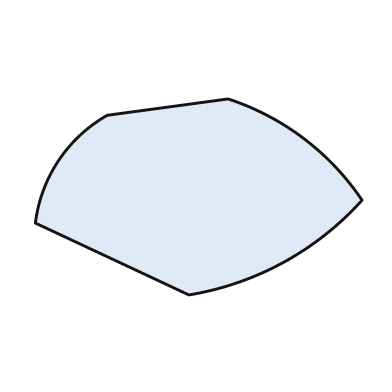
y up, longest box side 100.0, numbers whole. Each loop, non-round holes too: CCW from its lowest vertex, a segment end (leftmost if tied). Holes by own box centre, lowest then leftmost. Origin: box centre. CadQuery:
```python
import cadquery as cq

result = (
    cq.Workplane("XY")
    .moveTo(-3.0, -30.0)
    .threePointArc((26.0, -20.0), (50.0, -1.0))
    .threePointArc((32.0, 18.0), (9.0, 30.0))
    .lineTo(-28.0, 25.0)
    .threePointArc((-43.0, 11.0), (-50.0, -8.0))
    .close()
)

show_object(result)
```